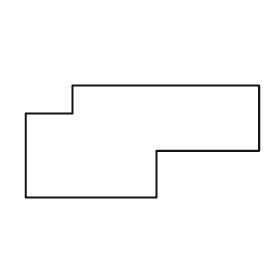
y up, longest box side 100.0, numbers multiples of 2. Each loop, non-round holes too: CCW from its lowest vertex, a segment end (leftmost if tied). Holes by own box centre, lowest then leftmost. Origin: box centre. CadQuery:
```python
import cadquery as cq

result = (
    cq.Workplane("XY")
    .moveTo(-50.0, -24.0)
    .lineTo(6.0, -24.0)
    .lineTo(6.0, -4.0)
    .lineTo(50.0, -4.0)
    .lineTo(50.0, 24.0)
    .lineTo(-30.0, 24.0)
    .lineTo(-30.0, 12.0)
    .lineTo(-50.0, 12.0)
    .close()
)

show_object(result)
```